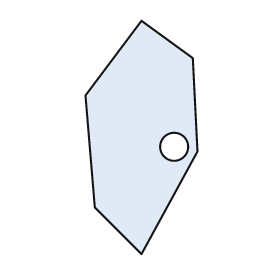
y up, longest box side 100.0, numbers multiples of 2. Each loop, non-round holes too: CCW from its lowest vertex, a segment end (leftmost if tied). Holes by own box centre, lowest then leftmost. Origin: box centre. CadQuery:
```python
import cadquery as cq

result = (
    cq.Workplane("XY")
    .moveTo(0.0, -50.0)
    .lineTo(24.0, -6.0)
    .lineTo(22.0, 34.0)
    .lineTo(0.0, 50.0)
    .lineTo(-24.0, 18.0)
    .lineTo(-20.0, -30.0)
    .close()
    .moveTo(14.0, -4.0)
    .circle(6.0)
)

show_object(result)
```